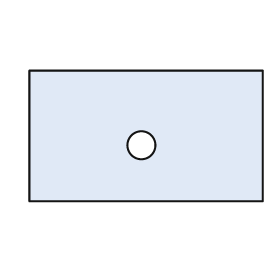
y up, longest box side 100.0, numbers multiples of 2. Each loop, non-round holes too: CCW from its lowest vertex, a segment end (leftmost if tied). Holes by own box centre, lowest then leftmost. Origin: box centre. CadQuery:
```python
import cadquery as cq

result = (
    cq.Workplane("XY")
    .moveTo(-50.0, -28.0)
    .lineTo(50.0, -28.0)
    .lineTo(50.0, 28.0)
    .lineTo(-50.0, 28.0)
    .close()
    .moveTo(-2.0, -4.0)
    .circle(6.0)
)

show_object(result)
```